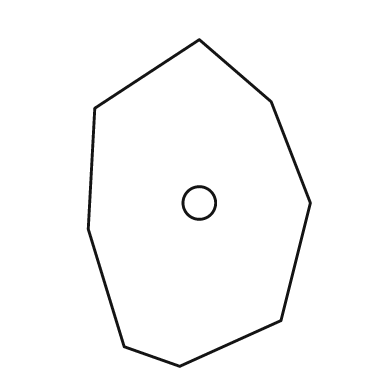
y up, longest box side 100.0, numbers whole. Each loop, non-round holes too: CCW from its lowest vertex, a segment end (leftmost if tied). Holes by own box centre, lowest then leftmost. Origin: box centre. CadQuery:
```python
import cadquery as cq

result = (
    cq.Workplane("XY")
    .moveTo(-6.0, -50.0)
    .lineTo(25.0, -36.0)
    .lineTo(34.0, 0.0)
    .lineTo(22.0, 31.0)
    .lineTo(0.0, 50.0)
    .lineTo(-32.0, 29.0)
    .lineTo(-34.0, -8.0)
    .lineTo(-23.0, -44.0)
    .close()
    .moveTo(0.0, 0.0)
    .circle(5.0)
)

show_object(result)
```